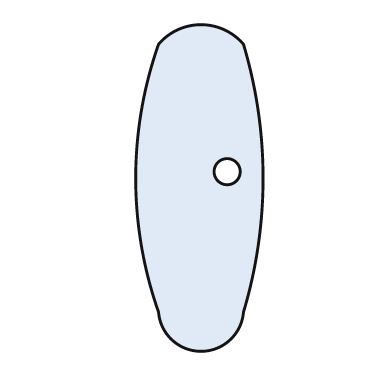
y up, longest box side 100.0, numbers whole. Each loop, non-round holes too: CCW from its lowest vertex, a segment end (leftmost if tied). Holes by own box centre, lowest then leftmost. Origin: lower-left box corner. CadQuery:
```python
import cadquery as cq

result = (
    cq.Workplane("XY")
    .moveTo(7.0, 12.0)
    .threePointArc((20.0, 0.0), (33.0, 12.0))
    .threePointArc((39.0, 53.0), (33.0, 94.0))
    .threePointArc((20.0, 100.0), (7.0, 94.0))
    .threePointArc((0.0, 53.0), (7.0, 12.0))
    .close()
    .moveTo(28.0, 55.0)
    .circle(4.0)
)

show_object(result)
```